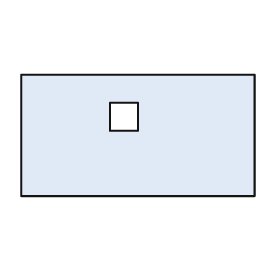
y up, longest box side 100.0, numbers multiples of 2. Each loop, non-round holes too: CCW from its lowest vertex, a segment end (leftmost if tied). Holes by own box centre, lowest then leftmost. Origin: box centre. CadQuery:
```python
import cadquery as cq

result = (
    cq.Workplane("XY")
    .moveTo(-50.0, -26.0)
    .lineTo(50.0, -26.0)
    .lineTo(50.0, 26.0)
    .lineTo(-50.0, 26.0)
    .close()
    .moveTo(-12.0, 2.0)
    .lineTo(0.0, 2.0)
    .lineTo(0.0, 14.0)
    .lineTo(-12.0, 14.0)
    .close()
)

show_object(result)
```